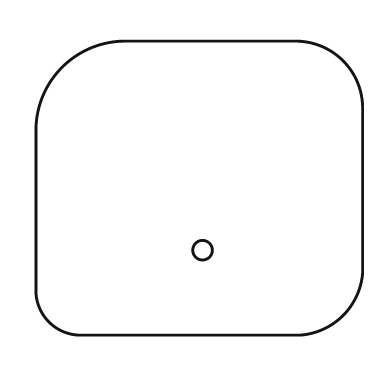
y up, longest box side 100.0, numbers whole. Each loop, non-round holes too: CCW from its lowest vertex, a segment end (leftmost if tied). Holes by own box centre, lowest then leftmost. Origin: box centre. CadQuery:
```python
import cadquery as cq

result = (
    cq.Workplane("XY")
    .moveTo(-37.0, -45.0)
    .lineTo(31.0, -45.0)
    .threePointArc((44.0, -39.0), (50.0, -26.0))
    .lineTo(50.0, 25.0)
    .threePointArc((44.0, 39.0), (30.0, 45.0))
    .lineTo(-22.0, 45.0)
    .threePointArc((-42.0, 37.0), (-50.0, 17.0))
    .lineTo(-50.0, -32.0)
    .threePointArc((-46.0, -41.0), (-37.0, -45.0))
    .close()
    .moveTo(1.0, -19.0)
    .circle(3.0)
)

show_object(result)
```